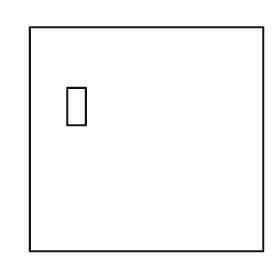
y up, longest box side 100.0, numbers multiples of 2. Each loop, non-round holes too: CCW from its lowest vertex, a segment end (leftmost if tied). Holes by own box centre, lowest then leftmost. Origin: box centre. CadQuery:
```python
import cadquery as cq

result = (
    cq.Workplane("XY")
    .moveTo(-50.0, -48.0)
    .lineTo(50.0, -48.0)
    .lineTo(50.0, 48.0)
    .lineTo(-50.0, 48.0)
    .close()
    .moveTo(-34.0, 6.0)
    .lineTo(-26.0, 6.0)
    .lineTo(-26.0, 22.0)
    .lineTo(-34.0, 22.0)
    .close()
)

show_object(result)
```